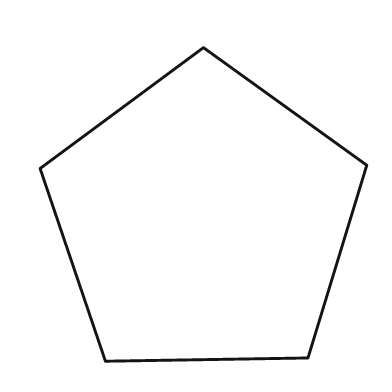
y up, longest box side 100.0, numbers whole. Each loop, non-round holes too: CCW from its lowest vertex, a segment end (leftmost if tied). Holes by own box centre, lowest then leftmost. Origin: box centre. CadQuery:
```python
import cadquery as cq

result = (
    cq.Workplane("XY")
    .moveTo(-30.0, -48.0)
    .lineTo(32.0, -47.0)
    .lineTo(50.0, 12.0)
    .lineTo(0.0, 48.0)
    .lineTo(-50.0, 11.0)
    .close()
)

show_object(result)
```